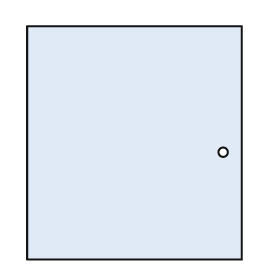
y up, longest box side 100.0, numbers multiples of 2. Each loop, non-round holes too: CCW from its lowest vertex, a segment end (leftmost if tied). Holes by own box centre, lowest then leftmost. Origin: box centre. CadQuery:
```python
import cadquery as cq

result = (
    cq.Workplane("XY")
    .moveTo(-46.0, -50.0)
    .lineTo(46.0, -50.0)
    .lineTo(46.0, 50.0)
    .lineTo(-46.0, 50.0)
    .close()
    .moveTo(38.0, -4.0)
    .circle(2.0)
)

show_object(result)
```